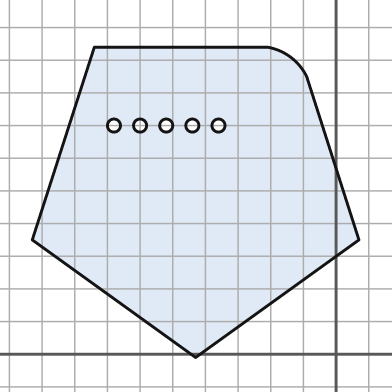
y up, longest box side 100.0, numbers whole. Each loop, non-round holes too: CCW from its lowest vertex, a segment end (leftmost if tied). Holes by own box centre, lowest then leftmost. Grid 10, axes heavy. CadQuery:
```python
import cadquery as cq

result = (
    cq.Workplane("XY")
    .moveTo(-43.0, -1.0)
    .lineTo(7.0, 35.0)
    .lineTo(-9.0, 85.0)
    .threePointArc((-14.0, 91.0), (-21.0, 94.0))
    .lineTo(-74.0, 94.0)
    .lineTo(-93.0, 35.0)
    .close()
    .moveTo(-68.0, 70.0)
    .circle(2.0)
    .moveTo(-60.0, 70.0)
    .circle(2.0)
    .moveTo(-52.0, 70.0)
    .circle(2.0)
    .moveTo(-44.0, 70.0)
    .circle(2.0)
    .moveTo(-36.0, 70.0)
    .circle(2.0)
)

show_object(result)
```